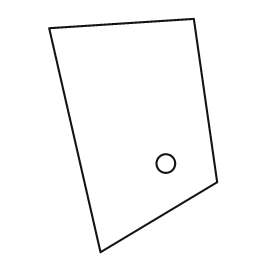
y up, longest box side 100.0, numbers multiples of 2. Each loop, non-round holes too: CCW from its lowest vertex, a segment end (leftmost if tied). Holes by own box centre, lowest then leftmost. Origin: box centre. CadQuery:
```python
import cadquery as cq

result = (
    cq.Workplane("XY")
    .moveTo(-14.0, -50.0)
    .lineTo(36.0, -20.0)
    .lineTo(26.0, 50.0)
    .lineTo(-36.0, 46.0)
    .close()
    .moveTo(14.0, -12.0)
    .circle(4.0)
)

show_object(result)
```